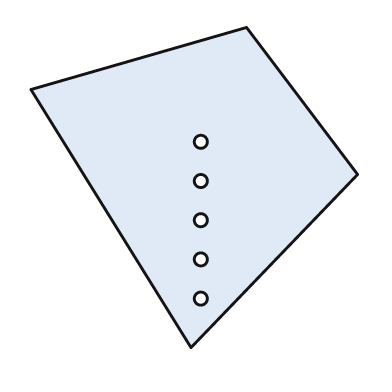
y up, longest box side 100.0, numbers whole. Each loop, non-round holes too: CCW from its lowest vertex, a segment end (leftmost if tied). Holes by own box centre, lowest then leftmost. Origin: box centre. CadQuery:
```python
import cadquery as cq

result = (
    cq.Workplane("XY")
    .moveTo(-1.0, -49.0)
    .lineTo(50.0, 4.0)
    .lineTo(16.0, 49.0)
    .lineTo(-50.0, 30.0)
    .close()
    .moveTo(2.0, -34.0)
    .circle(2.0)
    .moveTo(2.0, -22.0)
    .circle(2.0)
    .moveTo(2.0, -10.0)
    .circle(2.0)
    .moveTo(2.0, 2.0)
    .circle(2.0)
    .moveTo(2.0, 14.0)
    .circle(2.0)
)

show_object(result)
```